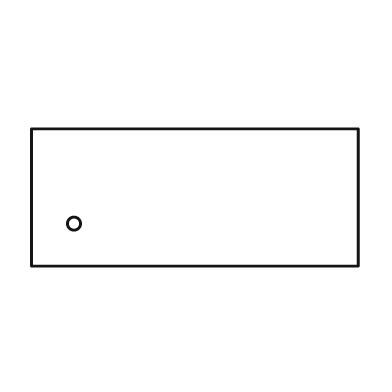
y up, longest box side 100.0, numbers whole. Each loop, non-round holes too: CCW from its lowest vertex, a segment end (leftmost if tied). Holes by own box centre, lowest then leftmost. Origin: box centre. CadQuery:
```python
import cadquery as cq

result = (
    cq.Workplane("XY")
    .moveTo(-50.0, -21.0)
    .lineTo(50.0, -21.0)
    .lineTo(50.0, 21.0)
    .lineTo(-50.0, 21.0)
    .close()
    .moveTo(-37.0, -8.0)
    .circle(2.0)
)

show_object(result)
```